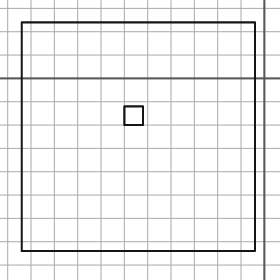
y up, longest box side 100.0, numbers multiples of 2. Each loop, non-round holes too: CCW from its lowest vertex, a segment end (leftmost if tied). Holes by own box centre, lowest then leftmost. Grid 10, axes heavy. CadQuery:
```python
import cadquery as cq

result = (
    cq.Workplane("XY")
    .moveTo(-104.0, -74.0)
    .lineTo(-4.0, -74.0)
    .lineTo(-4.0, 24.0)
    .lineTo(-104.0, 24.0)
    .close()
    .moveTo(-60.0, -20.0)
    .lineTo(-52.0, -20.0)
    .lineTo(-52.0, -12.0)
    .lineTo(-60.0, -12.0)
    .close()
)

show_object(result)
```